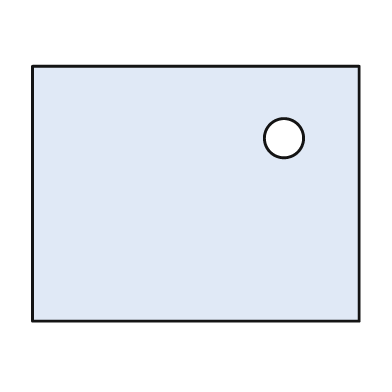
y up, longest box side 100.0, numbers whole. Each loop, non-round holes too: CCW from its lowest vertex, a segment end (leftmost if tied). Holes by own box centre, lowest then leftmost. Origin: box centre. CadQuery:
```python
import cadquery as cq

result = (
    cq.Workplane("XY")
    .moveTo(-50.0, -39.0)
    .lineTo(50.0, -39.0)
    .lineTo(50.0, 39.0)
    .lineTo(-50.0, 39.0)
    .close()
    .moveTo(27.0, 17.0)
    .circle(6.0)
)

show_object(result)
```